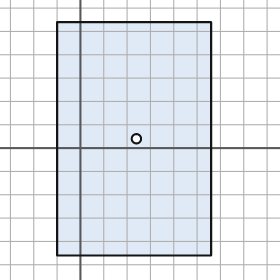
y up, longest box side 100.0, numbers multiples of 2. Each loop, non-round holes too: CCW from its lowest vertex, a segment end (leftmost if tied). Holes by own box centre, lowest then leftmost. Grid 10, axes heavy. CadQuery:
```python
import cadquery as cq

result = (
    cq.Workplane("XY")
    .moveTo(-10.0, -46.0)
    .lineTo(56.0, -46.0)
    .lineTo(56.0, 54.0)
    .lineTo(-10.0, 54.0)
    .close()
    .moveTo(24.0, 4.0)
    .circle(2.0)
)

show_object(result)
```